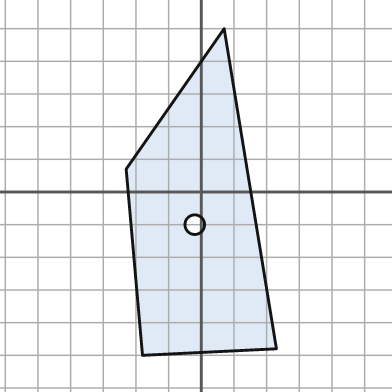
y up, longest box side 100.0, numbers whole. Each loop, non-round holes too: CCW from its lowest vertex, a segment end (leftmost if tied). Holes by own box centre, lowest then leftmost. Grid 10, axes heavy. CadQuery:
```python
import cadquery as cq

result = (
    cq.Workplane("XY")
    .moveTo(-18.0, -50.0)
    .lineTo(23.0, -48.0)
    .lineTo(7.0, 50.0)
    .lineTo(-23.0, 7.0)
    .close()
    .moveTo(-2.0, -10.0)
    .circle(3.0)
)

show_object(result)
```